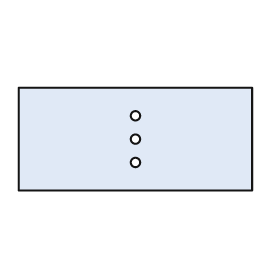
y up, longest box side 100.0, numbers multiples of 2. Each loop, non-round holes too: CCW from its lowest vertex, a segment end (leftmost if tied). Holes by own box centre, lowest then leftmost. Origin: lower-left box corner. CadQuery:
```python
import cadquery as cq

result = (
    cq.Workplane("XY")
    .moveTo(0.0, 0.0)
    .lineTo(100.0, 0.0)
    .lineTo(100.0, 44.0)
    .lineTo(0.0, 44.0)
    .close()
    .moveTo(50.0, 12.0)
    .circle(2.0)
    .moveTo(50.0, 22.0)
    .circle(2.0)
    .moveTo(50.0, 32.0)
    .circle(2.0)
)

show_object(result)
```